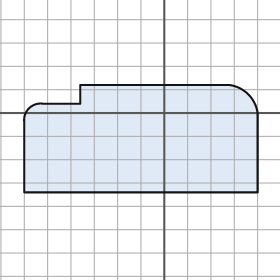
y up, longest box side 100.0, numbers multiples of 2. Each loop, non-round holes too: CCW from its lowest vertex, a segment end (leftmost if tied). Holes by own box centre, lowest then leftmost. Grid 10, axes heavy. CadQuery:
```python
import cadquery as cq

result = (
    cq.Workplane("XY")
    .moveTo(-60.0, -34.0)
    .lineTo(40.0, -34.0)
    .lineTo(40.0, 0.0)
    .threePointArc((36.0, 8.0), (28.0, 12.0))
    .lineTo(-36.0, 12.0)
    .lineTo(-36.0, 4.0)
    .lineTo(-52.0, 4.0)
    .threePointArc((-58.0, 2.0), (-60.0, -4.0))
    .close()
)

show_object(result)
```